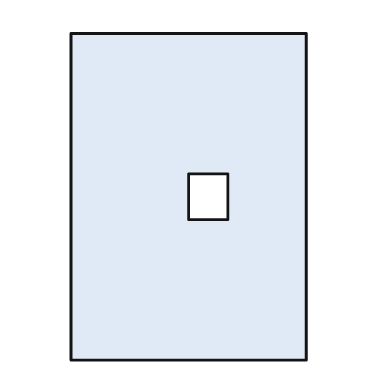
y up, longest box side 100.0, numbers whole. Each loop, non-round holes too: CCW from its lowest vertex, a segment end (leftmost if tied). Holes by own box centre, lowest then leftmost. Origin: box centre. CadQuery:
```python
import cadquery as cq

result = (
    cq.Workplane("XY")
    .moveTo(-36.0, -50.0)
    .lineTo(36.0, -50.0)
    .lineTo(36.0, 50.0)
    .lineTo(-36.0, 50.0)
    .close()
    .moveTo(0.0, -7.0)
    .lineTo(12.0, -7.0)
    .lineTo(12.0, 7.0)
    .lineTo(0.0, 7.0)
    .close()
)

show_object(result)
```